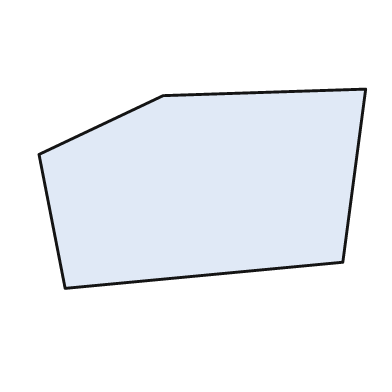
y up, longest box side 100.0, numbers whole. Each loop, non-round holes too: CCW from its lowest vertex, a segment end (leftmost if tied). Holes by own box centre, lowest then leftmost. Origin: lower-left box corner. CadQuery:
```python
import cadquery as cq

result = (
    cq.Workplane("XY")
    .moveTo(8.0, 0.0)
    .lineTo(93.0, 8.0)
    .lineTo(100.0, 61.0)
    .lineTo(38.0, 59.0)
    .lineTo(0.0, 41.0)
    .close()
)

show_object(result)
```